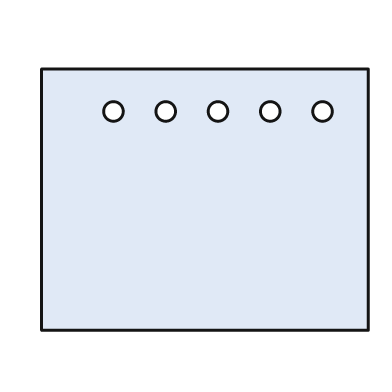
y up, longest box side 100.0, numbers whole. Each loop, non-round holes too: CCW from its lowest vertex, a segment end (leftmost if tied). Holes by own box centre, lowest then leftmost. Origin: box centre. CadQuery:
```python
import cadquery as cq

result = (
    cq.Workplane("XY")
    .moveTo(-50.0, -40.0)
    .lineTo(50.0, -40.0)
    .lineTo(50.0, 40.0)
    .lineTo(-50.0, 40.0)
    .close()
    .moveTo(-28.0, 27.0)
    .circle(3.0)
    .moveTo(-12.0, 27.0)
    .circle(3.0)
    .moveTo(4.0, 27.0)
    .circle(3.0)
    .moveTo(20.0, 27.0)
    .circle(3.0)
    .moveTo(36.0, 27.0)
    .circle(3.0)
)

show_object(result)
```